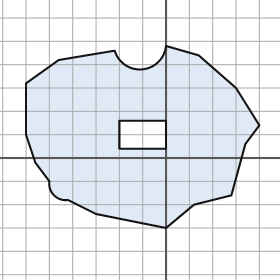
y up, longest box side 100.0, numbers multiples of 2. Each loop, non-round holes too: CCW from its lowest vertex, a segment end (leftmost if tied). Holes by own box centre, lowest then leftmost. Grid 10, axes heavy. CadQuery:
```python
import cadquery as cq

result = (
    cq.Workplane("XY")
    .moveTo(0.0, -30.0)
    .lineTo(12.0, -20.0)
    .lineTo(28.0, -16.0)
    .lineTo(34.0, 6.0)
    .lineTo(40.0, 14.0)
    .lineTo(30.0, 30.0)
    .lineTo(14.0, 44.0)
    .lineTo(0.0, 48.0)
    .threePointArc((-10.0, 38.0), (-22.0, 46.0))
    .lineTo(-46.0, 42.0)
    .lineTo(-60.0, 32.0)
    .lineTo(-60.0, 10.0)
    .lineTo(-56.0, -2.0)
    .lineTo(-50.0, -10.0)
    .threePointArc((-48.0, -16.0), (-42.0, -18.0))
    .lineTo(-30.0, -24.0)
    .close()
    .moveTo(-20.0, 4.0)
    .lineTo(0.0, 4.0)
    .lineTo(0.0, 16.0)
    .lineTo(-20.0, 16.0)
    .close()
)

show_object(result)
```